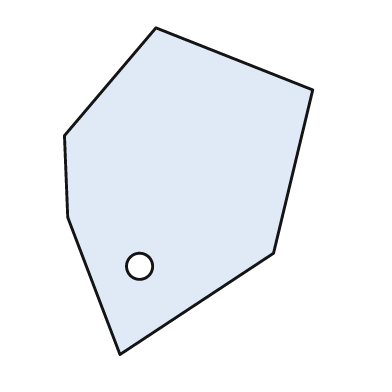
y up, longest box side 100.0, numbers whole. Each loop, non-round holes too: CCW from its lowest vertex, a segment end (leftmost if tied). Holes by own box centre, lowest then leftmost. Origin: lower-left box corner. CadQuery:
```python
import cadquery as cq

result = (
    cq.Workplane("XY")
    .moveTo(17.0, 0.0)
    .lineTo(64.0, 31.0)
    .lineTo(76.0, 81.0)
    .lineTo(28.0, 100.0)
    .lineTo(0.0, 67.0)
    .lineTo(1.0, 42.0)
    .close()
    .moveTo(23.0, 27.0)
    .circle(4.0)
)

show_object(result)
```